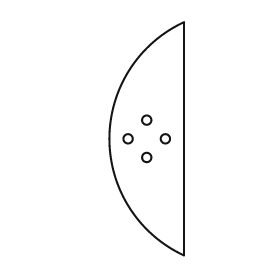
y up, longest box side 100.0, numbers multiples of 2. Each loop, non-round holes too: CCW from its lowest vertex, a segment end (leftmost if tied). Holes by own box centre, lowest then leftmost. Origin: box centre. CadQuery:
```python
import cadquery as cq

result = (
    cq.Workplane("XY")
    .moveTo(16.0, -50.0)
    .lineTo(16.0, 50.0)
    .threePointArc((-16.0, 0.0), (16.0, -50.0))
    .close()
    .moveTo(0.0, -8.0)
    .circle(2.0)
    .moveTo(-8.0, 0.0)
    .circle(2.0)
    .moveTo(8.0, 0.0)
    .circle(2.0)
    .moveTo(0.0, 8.0)
    .circle(2.0)
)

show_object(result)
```